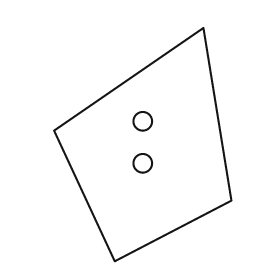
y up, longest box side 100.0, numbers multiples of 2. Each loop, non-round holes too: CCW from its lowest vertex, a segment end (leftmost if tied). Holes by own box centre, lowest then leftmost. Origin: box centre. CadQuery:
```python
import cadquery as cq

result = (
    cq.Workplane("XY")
    .moveTo(-12.0, -50.0)
    .lineTo(38.0, -24.0)
    .lineTo(26.0, 50.0)
    .lineTo(-38.0, 6.0)
    .close()
    .moveTo(0.0, -8.0)
    .circle(4.0)
    .moveTo(0.0, 10.0)
    .circle(4.0)
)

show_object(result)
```